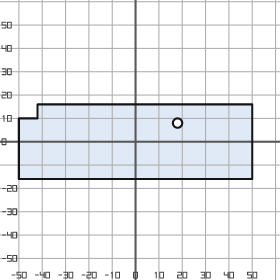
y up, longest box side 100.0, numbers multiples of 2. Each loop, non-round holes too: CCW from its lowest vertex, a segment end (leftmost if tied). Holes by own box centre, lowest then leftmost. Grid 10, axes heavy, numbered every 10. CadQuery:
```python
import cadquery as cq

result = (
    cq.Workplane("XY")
    .moveTo(-50.0, -16.0)
    .lineTo(50.0, -16.0)
    .lineTo(50.0, 16.0)
    .lineTo(-42.0, 16.0)
    .lineTo(-42.0, 10.0)
    .lineTo(-50.0, 10.0)
    .close()
    .moveTo(18.0, 8.0)
    .circle(2.0)
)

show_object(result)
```